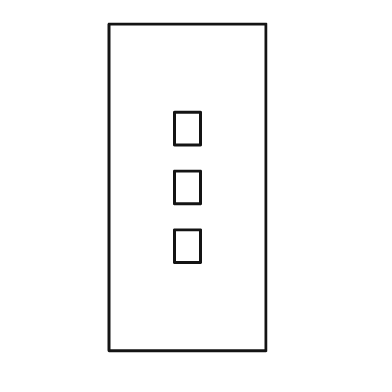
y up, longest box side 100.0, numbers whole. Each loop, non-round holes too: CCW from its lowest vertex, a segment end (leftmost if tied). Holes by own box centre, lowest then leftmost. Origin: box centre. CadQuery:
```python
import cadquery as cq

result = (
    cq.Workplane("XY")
    .moveTo(-24.0, -50.0)
    .lineTo(24.0, -50.0)
    .lineTo(24.0, 50.0)
    .lineTo(-24.0, 50.0)
    .close()
    .moveTo(-4.0, -23.0)
    .lineTo(4.0, -23.0)
    .lineTo(4.0, -13.0)
    .lineTo(-4.0, -13.0)
    .close()
    .moveTo(-4.0, -5.0)
    .lineTo(4.0, -5.0)
    .lineTo(4.0, 5.0)
    .lineTo(-4.0, 5.0)
    .close()
    .moveTo(-4.0, 13.0)
    .lineTo(4.0, 13.0)
    .lineTo(4.0, 23.0)
    .lineTo(-4.0, 23.0)
    .close()
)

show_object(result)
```